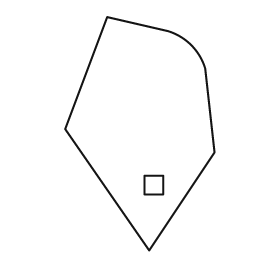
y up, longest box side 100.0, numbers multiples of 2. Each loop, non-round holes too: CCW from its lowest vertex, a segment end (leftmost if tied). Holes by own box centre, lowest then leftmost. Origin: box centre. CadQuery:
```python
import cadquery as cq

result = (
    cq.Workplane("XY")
    .moveTo(4.0, -50.0)
    .lineTo(32.0, -8.0)
    .lineTo(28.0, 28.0)
    .threePointArc((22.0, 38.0), (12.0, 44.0))
    .lineTo(-14.0, 50.0)
    .lineTo(-32.0, 2.0)
    .close()
    .moveTo(2.0, -26.0)
    .lineTo(10.0, -26.0)
    .lineTo(10.0, -18.0)
    .lineTo(2.0, -18.0)
    .close()
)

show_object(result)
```